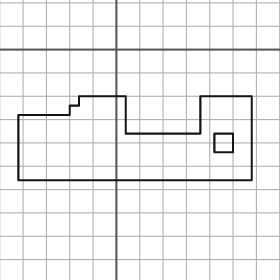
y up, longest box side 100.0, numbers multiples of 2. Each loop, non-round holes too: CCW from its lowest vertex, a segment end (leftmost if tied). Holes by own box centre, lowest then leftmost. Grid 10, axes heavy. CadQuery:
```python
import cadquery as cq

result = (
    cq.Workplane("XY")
    .moveTo(-42.0, -56.0)
    .lineTo(58.0, -56.0)
    .lineTo(58.0, -20.0)
    .lineTo(36.0, -20.0)
    .lineTo(36.0, -36.0)
    .lineTo(4.0, -36.0)
    .lineTo(4.0, -20.0)
    .lineTo(-16.0, -20.0)
    .lineTo(-16.0, -24.0)
    .lineTo(-20.0, -24.0)
    .lineTo(-20.0, -28.0)
    .lineTo(-42.0, -28.0)
    .close()
    .moveTo(42.0, -44.0)
    .lineTo(50.0, -44.0)
    .lineTo(50.0, -36.0)
    .lineTo(42.0, -36.0)
    .close()
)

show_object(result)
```